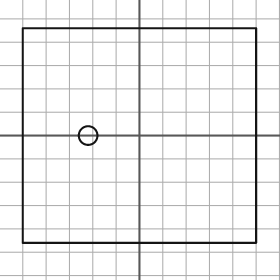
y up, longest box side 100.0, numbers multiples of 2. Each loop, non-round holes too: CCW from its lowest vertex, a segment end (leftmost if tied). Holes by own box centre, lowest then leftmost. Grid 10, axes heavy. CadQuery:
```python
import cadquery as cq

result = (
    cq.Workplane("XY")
    .moveTo(-50.0, -46.0)
    .lineTo(50.0, -46.0)
    .lineTo(50.0, 46.0)
    .lineTo(-50.0, 46.0)
    .close()
    .moveTo(-22.0, 0.0)
    .circle(4.0)
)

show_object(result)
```